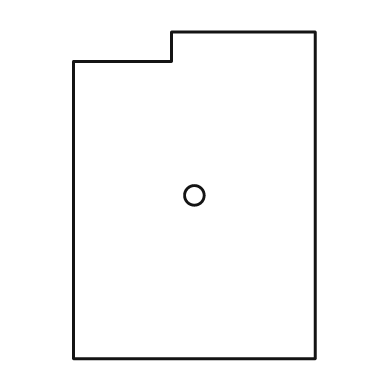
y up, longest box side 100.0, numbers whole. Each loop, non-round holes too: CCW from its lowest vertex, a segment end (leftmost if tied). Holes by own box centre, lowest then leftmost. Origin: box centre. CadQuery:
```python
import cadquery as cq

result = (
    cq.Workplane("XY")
    .moveTo(-37.0, -50.0)
    .lineTo(37.0, -50.0)
    .lineTo(37.0, 50.0)
    .lineTo(-7.0, 50.0)
    .lineTo(-7.0, 41.0)
    .lineTo(-37.0, 41.0)
    .close()
    .moveTo(0.0, 0.0)
    .circle(3.0)
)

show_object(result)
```